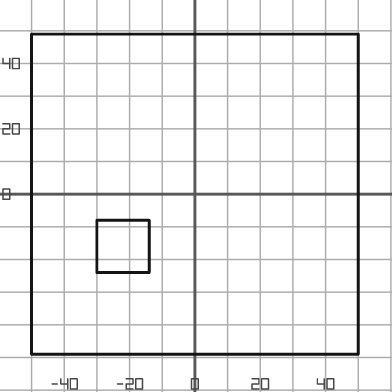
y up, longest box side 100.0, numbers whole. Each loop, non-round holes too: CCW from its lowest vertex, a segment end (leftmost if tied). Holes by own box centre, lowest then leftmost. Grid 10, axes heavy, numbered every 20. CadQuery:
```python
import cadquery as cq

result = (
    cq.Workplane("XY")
    .moveTo(-50.0, -49.0)
    .lineTo(50.0, -49.0)
    .lineTo(50.0, 49.0)
    .lineTo(-50.0, 49.0)
    .close()
    .moveTo(-30.0, -24.0)
    .lineTo(-14.0, -24.0)
    .lineTo(-14.0, -8.0)
    .lineTo(-30.0, -8.0)
    .close()
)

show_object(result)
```